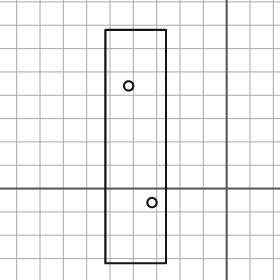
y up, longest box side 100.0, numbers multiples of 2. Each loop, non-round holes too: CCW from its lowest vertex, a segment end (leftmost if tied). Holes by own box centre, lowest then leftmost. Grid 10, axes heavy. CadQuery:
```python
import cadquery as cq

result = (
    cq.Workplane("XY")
    .moveTo(-52.0, -32.0)
    .lineTo(-26.0, -32.0)
    .lineTo(-26.0, 68.0)
    .lineTo(-52.0, 68.0)
    .close()
    .moveTo(-32.0, -6.0)
    .circle(2.0)
    .moveTo(-42.0, 44.0)
    .circle(2.0)
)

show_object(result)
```